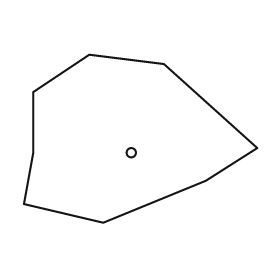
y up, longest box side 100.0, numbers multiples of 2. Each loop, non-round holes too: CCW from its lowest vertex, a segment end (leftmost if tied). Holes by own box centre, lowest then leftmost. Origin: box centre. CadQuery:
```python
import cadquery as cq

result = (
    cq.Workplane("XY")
    .moveTo(-16.0, -36.0)
    .lineTo(28.0, -18.0)
    .lineTo(50.0, -4.0)
    .lineTo(10.0, 32.0)
    .lineTo(-22.0, 36.0)
    .lineTo(-46.0, 20.0)
    .lineTo(-46.0, -6.0)
    .lineTo(-50.0, -28.0)
    .close()
    .moveTo(-4.0, -6.0)
    .circle(2.0)
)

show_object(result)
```